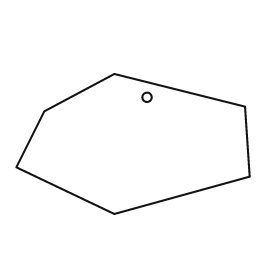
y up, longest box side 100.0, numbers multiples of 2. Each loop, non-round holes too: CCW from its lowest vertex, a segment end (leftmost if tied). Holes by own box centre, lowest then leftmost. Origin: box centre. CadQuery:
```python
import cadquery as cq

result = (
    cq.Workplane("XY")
    .moveTo(-8.0, -30.0)
    .lineTo(50.0, -14.0)
    .lineTo(48.0, 16.0)
    .lineTo(-8.0, 30.0)
    .lineTo(-38.0, 14.0)
    .lineTo(-50.0, -10.0)
    .close()
    .moveTo(6.0, 20.0)
    .circle(2.0)
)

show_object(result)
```